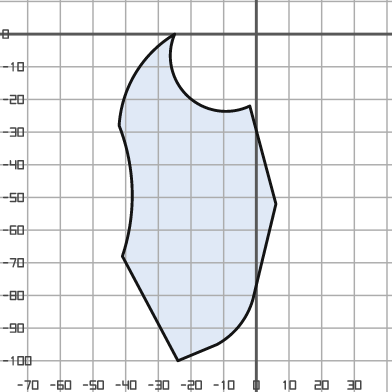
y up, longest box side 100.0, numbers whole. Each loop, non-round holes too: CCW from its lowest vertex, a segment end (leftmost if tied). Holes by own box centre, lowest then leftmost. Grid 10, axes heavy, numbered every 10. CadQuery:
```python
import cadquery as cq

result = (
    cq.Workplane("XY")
    .moveTo(-24.0, -100.0)
    .lineTo(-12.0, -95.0)
    .threePointArc((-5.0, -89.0), (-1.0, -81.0))
    .lineTo(6.0, -52.0)
    .lineTo(-2.0, -22.0)
    .threePointArc((-21.0, -19.0), (-25.0, 0.0))
    .threePointArc((-37.0, -12.0), (-42.0, -28.0))
    .threePointArc((-38.0, -48.0), (-41.0, -68.0))
    .close()
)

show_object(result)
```